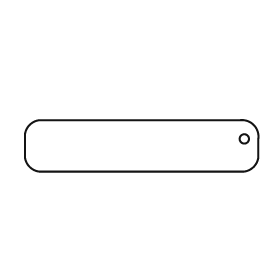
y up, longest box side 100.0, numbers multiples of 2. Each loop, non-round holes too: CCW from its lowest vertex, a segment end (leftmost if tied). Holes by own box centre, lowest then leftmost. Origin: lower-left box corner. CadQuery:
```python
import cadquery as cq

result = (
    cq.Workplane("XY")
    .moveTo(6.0, 0.0)
    .lineTo(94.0, 0.0)
    .threePointArc((98.0, 2.0), (100.0, 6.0))
    .lineTo(100.0, 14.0)
    .threePointArc((98.0, 20.0), (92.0, 22.0))
    .lineTo(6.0, 22.0)
    .threePointArc((2.0, 20.0), (0.0, 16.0))
    .lineTo(0.0, 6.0)
    .threePointArc((2.0, 2.0), (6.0, 0.0))
    .close()
    .moveTo(94.0, 14.0)
    .circle(2.0)
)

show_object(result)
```